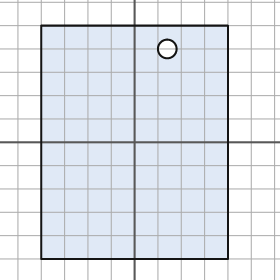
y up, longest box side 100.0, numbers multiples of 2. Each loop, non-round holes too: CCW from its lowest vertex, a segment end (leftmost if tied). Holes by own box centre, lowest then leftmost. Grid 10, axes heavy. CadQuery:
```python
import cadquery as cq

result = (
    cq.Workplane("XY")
    .moveTo(-40.0, -50.0)
    .lineTo(40.0, -50.0)
    .lineTo(40.0, 50.0)
    .lineTo(-40.0, 50.0)
    .close()
    .moveTo(14.0, 40.0)
    .circle(4.0)
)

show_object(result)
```